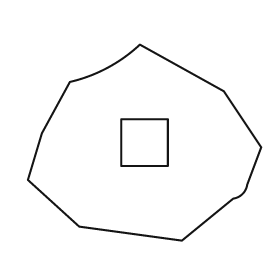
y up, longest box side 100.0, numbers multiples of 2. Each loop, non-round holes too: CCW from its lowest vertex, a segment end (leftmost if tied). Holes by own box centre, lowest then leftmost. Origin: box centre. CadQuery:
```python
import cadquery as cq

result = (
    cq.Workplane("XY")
    .moveTo(16.0, -42.0)
    .lineTo(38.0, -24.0)
    .threePointArc((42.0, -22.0), (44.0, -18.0))
    .lineTo(50.0, -2.0)
    .lineTo(34.0, 22.0)
    .lineTo(-2.0, 42.0)
    .threePointArc((-16.0, 32.0), (-32.0, 26.0))
    .lineTo(-44.0, 4.0)
    .lineTo(-50.0, -16.0)
    .lineTo(-28.0, -36.0)
    .close()
    .moveTo(-10.0, -10.0)
    .lineTo(10.0, -10.0)
    .lineTo(10.0, 10.0)
    .lineTo(-10.0, 10.0)
    .close()
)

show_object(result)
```